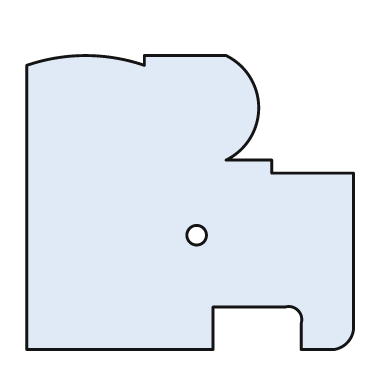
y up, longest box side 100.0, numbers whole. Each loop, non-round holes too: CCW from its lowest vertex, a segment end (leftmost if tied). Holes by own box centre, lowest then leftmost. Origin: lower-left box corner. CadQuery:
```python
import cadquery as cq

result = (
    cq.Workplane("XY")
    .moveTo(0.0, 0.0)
    .lineTo(57.0, 0.0)
    .lineTo(57.0, 13.0)
    .lineTo(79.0, 13.0)
    .threePointArc((83.0, 12.0), (84.0, 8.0))
    .lineTo(84.0, 0.0)
    .lineTo(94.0, 0.0)
    .threePointArc((98.0, 2.0), (100.0, 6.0))
    .lineTo(100.0, 54.0)
    .lineTo(75.0, 54.0)
    .lineTo(75.0, 58.0)
    .lineTo(61.0, 58.0)
    .threePointArc((71.0, 74.0), (61.0, 90.0))
    .lineTo(36.0, 90.0)
    .lineTo(36.0, 87.0)
    .threePointArc((18.0, 90.0), (0.0, 87.0))
    .close()
    .moveTo(52.0, 35.0)
    .circle(3.0)
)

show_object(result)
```